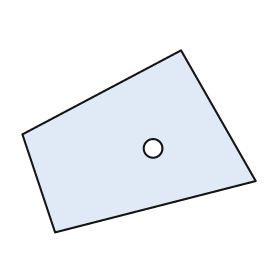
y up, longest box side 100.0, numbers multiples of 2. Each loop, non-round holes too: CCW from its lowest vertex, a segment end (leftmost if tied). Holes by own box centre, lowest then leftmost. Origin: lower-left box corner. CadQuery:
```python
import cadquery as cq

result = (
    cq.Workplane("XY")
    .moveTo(14.0, 0.0)
    .lineTo(100.0, 22.0)
    .lineTo(68.0, 78.0)
    .lineTo(0.0, 42.0)
    .close()
    .moveTo(56.0, 36.0)
    .circle(4.0)
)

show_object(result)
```